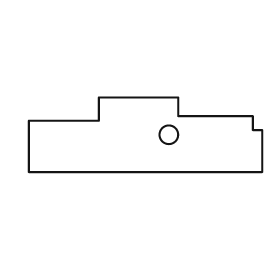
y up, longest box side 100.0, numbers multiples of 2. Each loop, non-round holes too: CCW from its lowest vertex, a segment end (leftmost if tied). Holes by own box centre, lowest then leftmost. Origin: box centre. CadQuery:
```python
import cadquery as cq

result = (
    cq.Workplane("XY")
    .moveTo(-50.0, -16.0)
    .lineTo(50.0, -16.0)
    .lineTo(50.0, 2.0)
    .lineTo(46.0, 2.0)
    .lineTo(46.0, 8.0)
    .lineTo(14.0, 8.0)
    .lineTo(14.0, 16.0)
    .lineTo(-20.0, 16.0)
    .lineTo(-20.0, 6.0)
    .lineTo(-50.0, 6.0)
    .close()
    .moveTo(10.0, 0.0)
    .circle(4.0)
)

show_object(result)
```